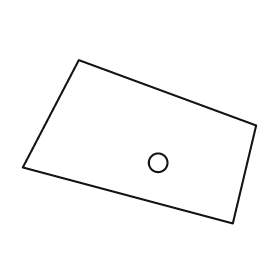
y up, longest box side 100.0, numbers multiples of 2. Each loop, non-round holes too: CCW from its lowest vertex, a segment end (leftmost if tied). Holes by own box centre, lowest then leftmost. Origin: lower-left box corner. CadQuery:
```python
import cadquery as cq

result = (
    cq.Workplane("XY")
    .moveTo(90.0, 0.0)
    .lineTo(100.0, 42.0)
    .lineTo(24.0, 70.0)
    .lineTo(0.0, 24.0)
    .close()
    .moveTo(58.0, 26.0)
    .circle(4.0)
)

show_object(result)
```